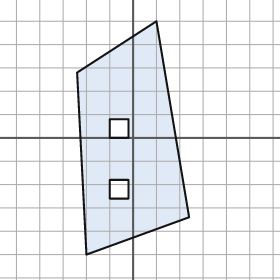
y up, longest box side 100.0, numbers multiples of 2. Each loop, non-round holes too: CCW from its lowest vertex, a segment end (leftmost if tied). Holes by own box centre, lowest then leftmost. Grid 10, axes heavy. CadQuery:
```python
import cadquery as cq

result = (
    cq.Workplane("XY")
    .moveTo(-20.0, -50.0)
    .lineTo(24.0, -34.0)
    .lineTo(10.0, 50.0)
    .lineTo(-24.0, 28.0)
    .close()
    .moveTo(-10.0, -26.0)
    .lineTo(-2.0, -26.0)
    .lineTo(-2.0, -18.0)
    .lineTo(-10.0, -18.0)
    .close()
    .moveTo(-10.0, 0.0)
    .lineTo(-2.0, 0.0)
    .lineTo(-2.0, 8.0)
    .lineTo(-10.0, 8.0)
    .close()
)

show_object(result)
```